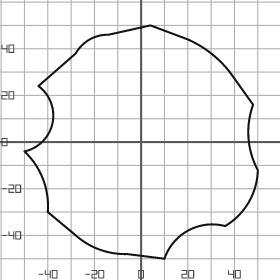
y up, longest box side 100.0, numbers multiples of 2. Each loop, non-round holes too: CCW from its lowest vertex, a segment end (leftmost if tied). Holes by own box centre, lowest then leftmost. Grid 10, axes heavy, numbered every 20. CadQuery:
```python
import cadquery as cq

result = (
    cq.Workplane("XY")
    .moveTo(10.0, -50.0)
    .threePointArc((20.0, -38.0), (36.0, -36.0))
    .threePointArc((46.0, -26.0), (50.0, -12.0))
    .threePointArc((46.0, 2.0), (48.0, 16.0))
    .lineTo(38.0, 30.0)
    .threePointArc((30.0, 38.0), (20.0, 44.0))
    .lineTo(4.0, 50.0)
    .lineTo(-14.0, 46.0)
    .threePointArc((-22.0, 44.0), (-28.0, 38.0))
    .lineTo(-44.0, 24.0)
    .threePointArc((-38.0, 8.0), (-50.0, -4.0))
    .threePointArc((-42.0, -16.0), (-40.0, -30.0))
    .lineTo(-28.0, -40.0)
    .threePointArc((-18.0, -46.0), (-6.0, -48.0))
    .close()
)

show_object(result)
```